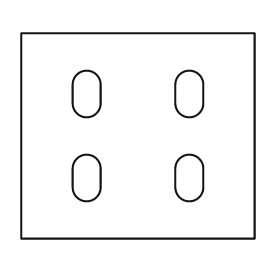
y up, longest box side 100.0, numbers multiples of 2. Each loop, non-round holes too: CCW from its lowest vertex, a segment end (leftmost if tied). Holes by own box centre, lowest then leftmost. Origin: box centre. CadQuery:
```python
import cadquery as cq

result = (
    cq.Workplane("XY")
    .moveTo(-50.0, -44.0)
    .lineTo(50.0, -44.0)
    .lineTo(50.0, 44.0)
    .lineTo(-50.0, 44.0)
    .close()
    .moveTo(-28.0, -22.0)
    .threePointArc((-22.0, -28.0), (-16.0, -22.0))
    .lineTo(-16.0, -14.0)
    .threePointArc((-22.0, -8.0), (-28.0, -14.0))
    .close()
    .moveTo(16.0, -22.0)
    .threePointArc((22.0, -28.0), (28.0, -22.0))
    .lineTo(28.0, -14.0)
    .threePointArc((22.0, -8.0), (16.0, -14.0))
    .close()
    .moveTo(-28.0, 14.0)
    .threePointArc((-22.0, 8.0), (-16.0, 14.0))
    .lineTo(-16.0, 22.0)
    .threePointArc((-22.0, 28.0), (-28.0, 22.0))
    .close()
    .moveTo(16.0, 14.0)
    .threePointArc((22.0, 8.0), (28.0, 14.0))
    .lineTo(28.0, 22.0)
    .threePointArc((22.0, 28.0), (16.0, 22.0))
    .close()
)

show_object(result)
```